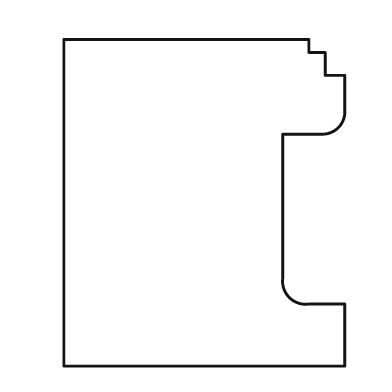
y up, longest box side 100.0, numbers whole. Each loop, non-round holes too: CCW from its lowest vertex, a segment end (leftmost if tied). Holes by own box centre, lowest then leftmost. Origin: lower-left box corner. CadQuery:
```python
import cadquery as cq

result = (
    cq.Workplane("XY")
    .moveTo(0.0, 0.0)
    .lineTo(86.0, 0.0)
    .lineTo(86.0, 19.0)
    .lineTo(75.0, 19.0)
    .threePointArc((69.0, 21.0), (67.0, 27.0))
    .lineTo(67.0, 71.0)
    .lineTo(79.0, 71.0)
    .threePointArc((84.0, 73.0), (86.0, 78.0))
    .lineTo(86.0, 89.0)
    .lineTo(80.0, 89.0)
    .lineTo(80.0, 96.0)
    .lineTo(75.0, 96.0)
    .lineTo(75.0, 100.0)
    .lineTo(0.0, 100.0)
    .close()
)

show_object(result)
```